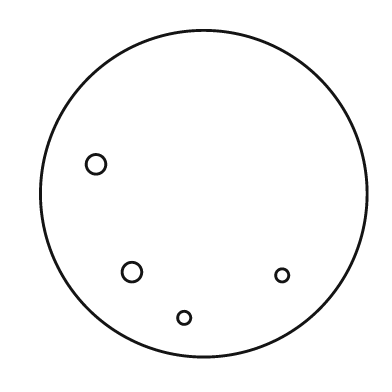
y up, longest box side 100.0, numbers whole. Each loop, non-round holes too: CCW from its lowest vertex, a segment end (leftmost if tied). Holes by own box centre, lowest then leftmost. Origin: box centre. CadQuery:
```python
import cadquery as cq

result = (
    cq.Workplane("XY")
    .moveTo(0.0, 0.0)
    .circle(50.0)
    .moveTo(-6.0, -38.0)
    .circle(2.0)
    .moveTo(24.0, -25.0)
    .circle(2.0)
    .moveTo(-22.0, -24.0)
    .circle(3.0)
    .moveTo(-33.0, 9.0)
    .circle(3.0)
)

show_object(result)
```